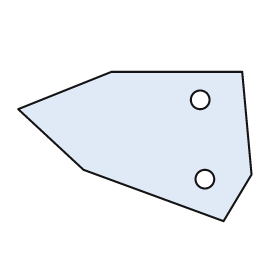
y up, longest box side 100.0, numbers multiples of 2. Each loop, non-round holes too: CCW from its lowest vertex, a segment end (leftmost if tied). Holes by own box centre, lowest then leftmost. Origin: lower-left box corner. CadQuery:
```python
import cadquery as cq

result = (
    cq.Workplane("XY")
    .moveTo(88.0, 0.0)
    .lineTo(100.0, 20.0)
    .lineTo(96.0, 64.0)
    .lineTo(40.0, 64.0)
    .lineTo(0.0, 48.0)
    .lineTo(28.0, 22.0)
    .close()
    .moveTo(80.0, 18.0)
    .circle(4.0)
    .moveTo(78.0, 52.0)
    .circle(4.0)
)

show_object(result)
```